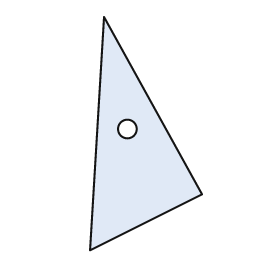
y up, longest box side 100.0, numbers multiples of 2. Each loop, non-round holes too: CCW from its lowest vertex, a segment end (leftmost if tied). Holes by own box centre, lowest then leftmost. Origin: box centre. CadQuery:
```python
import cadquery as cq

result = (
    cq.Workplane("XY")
    .moveTo(-24.0, -50.0)
    .lineTo(24.0, -26.0)
    .lineTo(-18.0, 50.0)
    .close()
    .moveTo(-8.0, 2.0)
    .circle(4.0)
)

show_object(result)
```